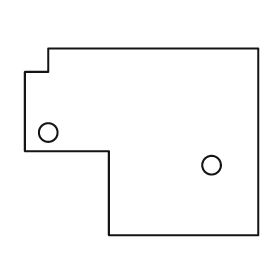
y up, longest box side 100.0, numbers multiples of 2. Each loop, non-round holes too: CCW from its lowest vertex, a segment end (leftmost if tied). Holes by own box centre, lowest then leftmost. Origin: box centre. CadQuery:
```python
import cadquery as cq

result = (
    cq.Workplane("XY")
    .moveTo(-14.0, -40.0)
    .lineTo(50.0, -40.0)
    .lineTo(50.0, 40.0)
    .lineTo(-40.0, 40.0)
    .lineTo(-40.0, 30.0)
    .lineTo(-50.0, 30.0)
    .lineTo(-50.0, -4.0)
    .lineTo(-14.0, -4.0)
    .close()
    .moveTo(30.0, -10.0)
    .circle(4.0)
    .moveTo(-40.0, 4.0)
    .circle(4.0)
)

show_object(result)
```